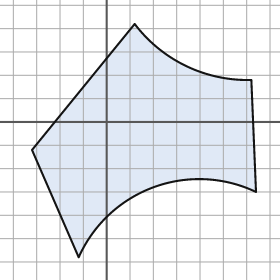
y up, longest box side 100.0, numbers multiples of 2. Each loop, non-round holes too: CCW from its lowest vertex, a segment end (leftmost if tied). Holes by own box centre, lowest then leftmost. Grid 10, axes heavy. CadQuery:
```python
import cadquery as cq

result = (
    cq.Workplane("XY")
    .moveTo(-12.0, -58.0)
    .threePointArc((20.0, -28.0), (64.0, -30.0))
    .lineTo(62.0, 18.0)
    .threePointArc((34.0, 24.0), (12.0, 42.0))
    .lineTo(-32.0, -12.0)
    .close()
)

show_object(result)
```